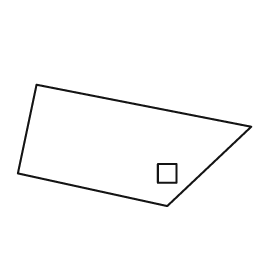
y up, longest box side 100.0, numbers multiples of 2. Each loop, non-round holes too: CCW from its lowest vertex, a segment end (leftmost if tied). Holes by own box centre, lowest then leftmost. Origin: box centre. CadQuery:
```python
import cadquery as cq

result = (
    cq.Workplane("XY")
    .moveTo(14.0, -26.0)
    .lineTo(50.0, 8.0)
    .lineTo(-42.0, 26.0)
    .lineTo(-50.0, -12.0)
    .close()
    .moveTo(10.0, -16.0)
    .lineTo(18.0, -16.0)
    .lineTo(18.0, -8.0)
    .lineTo(10.0, -8.0)
    .close()
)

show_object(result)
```